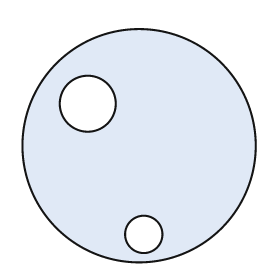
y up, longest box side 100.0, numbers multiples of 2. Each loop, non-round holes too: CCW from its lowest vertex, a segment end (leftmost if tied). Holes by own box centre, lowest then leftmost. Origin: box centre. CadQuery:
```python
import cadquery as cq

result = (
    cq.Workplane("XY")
    .moveTo(0.0, 0.0)
    .circle(50.0)
    .moveTo(2.0, -38.0)
    .circle(8.0)
    .moveTo(-22.0, 18.0)
    .circle(12.0)
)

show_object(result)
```